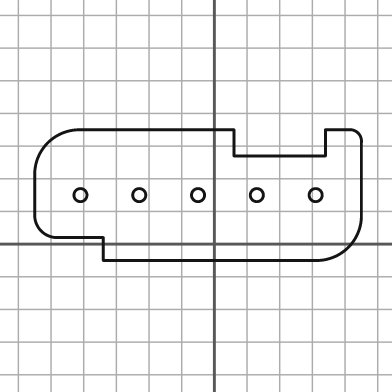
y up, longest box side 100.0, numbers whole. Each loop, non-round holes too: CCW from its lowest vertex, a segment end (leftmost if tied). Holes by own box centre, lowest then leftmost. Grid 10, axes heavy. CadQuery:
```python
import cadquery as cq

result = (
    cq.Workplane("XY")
    .moveTo(-34.0, -5.0)
    .lineTo(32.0, -5.0)
    .threePointArc((41.0, -1.0), (45.0, 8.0))
    .lineTo(45.0, 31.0)
    .threePointArc((44.0, 34.0), (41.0, 35.0))
    .lineTo(34.0, 35.0)
    .lineTo(34.0, 27.0)
    .lineTo(6.0, 27.0)
    .lineTo(6.0, 35.0)
    .lineTo(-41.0, 35.0)
    .threePointArc((-51.0, 31.0), (-55.0, 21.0))
    .lineTo(-55.0, 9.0)
    .threePointArc((-53.0, 4.0), (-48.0, 2.0))
    .lineTo(-34.0, 2.0)
    .close()
    .moveTo(-41.0, 15.0)
    .circle(2.0)
    .moveTo(-23.0, 15.0)
    .circle(2.0)
    .moveTo(-5.0, 15.0)
    .circle(2.0)
    .moveTo(13.0, 15.0)
    .circle(2.0)
    .moveTo(31.0, 15.0)
    .circle(2.0)
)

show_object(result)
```